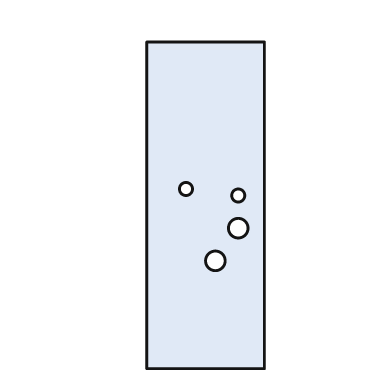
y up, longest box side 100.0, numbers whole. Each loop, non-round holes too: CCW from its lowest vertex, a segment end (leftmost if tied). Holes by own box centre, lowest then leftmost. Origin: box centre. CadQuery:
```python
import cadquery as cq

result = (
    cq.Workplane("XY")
    .moveTo(-18.0, -50.0)
    .lineTo(18.0, -50.0)
    .lineTo(18.0, 50.0)
    .lineTo(-18.0, 50.0)
    .close()
    .moveTo(3.0, -17.0)
    .circle(3.0)
    .moveTo(10.0, -7.0)
    .circle(3.0)
    .moveTo(10.0, 3.0)
    .circle(2.0)
    .moveTo(-6.0, 5.0)
    .circle(2.0)
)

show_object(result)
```